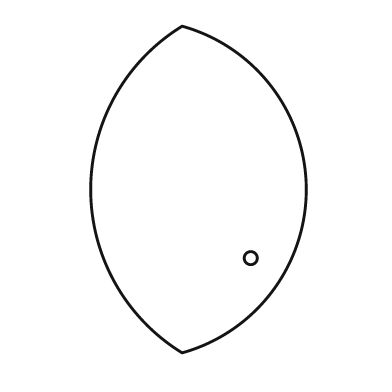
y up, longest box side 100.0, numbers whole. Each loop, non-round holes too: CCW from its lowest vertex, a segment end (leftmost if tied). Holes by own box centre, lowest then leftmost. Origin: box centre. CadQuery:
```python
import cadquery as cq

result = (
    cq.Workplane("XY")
    .moveTo(-5.0, -50.0)
    .threePointArc((33.0, 0.0), (-5.0, 50.0))
    .threePointArc((-33.0, 0.0), (-5.0, -50.0))
    .close()
    .moveTo(16.0, -21.0)
    .circle(2.0)
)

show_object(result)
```